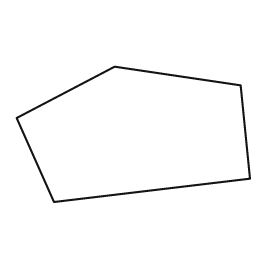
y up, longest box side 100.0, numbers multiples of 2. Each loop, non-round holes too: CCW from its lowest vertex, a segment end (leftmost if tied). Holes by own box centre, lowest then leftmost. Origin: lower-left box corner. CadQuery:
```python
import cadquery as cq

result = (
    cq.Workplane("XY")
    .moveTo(16.0, 0.0)
    .lineTo(100.0, 10.0)
    .lineTo(96.0, 50.0)
    .lineTo(42.0, 58.0)
    .lineTo(0.0, 36.0)
    .close()
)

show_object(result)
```